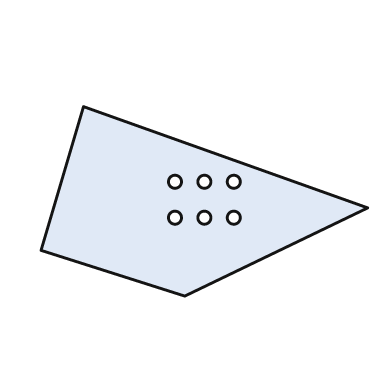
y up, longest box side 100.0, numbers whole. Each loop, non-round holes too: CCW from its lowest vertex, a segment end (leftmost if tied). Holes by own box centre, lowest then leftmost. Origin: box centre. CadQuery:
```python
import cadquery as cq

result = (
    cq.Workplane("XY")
    .moveTo(-6.0, -29.0)
    .lineTo(50.0, -2.0)
    .lineTo(-37.0, 29.0)
    .lineTo(-50.0, -15.0)
    .close()
    .moveTo(-9.0, -5.0)
    .circle(2.0)
    .moveTo(0.0, -5.0)
    .circle(2.0)
    .moveTo(9.0, -5.0)
    .circle(2.0)
    .moveTo(-9.0, 6.0)
    .circle(2.0)
    .moveTo(0.0, 6.0)
    .circle(2.0)
    .moveTo(9.0, 6.0)
    .circle(2.0)
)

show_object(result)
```